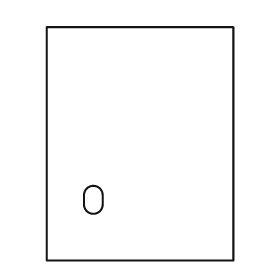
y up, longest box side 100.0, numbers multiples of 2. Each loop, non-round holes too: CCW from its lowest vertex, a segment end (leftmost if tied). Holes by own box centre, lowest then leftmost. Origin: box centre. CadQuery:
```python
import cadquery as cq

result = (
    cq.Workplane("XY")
    .moveTo(-40.0, -50.0)
    .lineTo(40.0, -50.0)
    .lineTo(40.0, 50.0)
    .lineTo(-40.0, 50.0)
    .close()
    .moveTo(-24.0, -26.0)
    .threePointArc((-20.0, -30.0), (-16.0, -26.0))
    .lineTo(-16.0, -22.0)
    .threePointArc((-20.0, -18.0), (-24.0, -22.0))
    .close()
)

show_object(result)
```